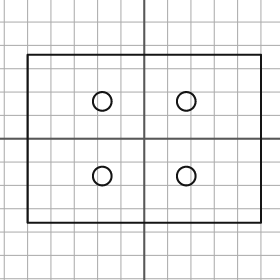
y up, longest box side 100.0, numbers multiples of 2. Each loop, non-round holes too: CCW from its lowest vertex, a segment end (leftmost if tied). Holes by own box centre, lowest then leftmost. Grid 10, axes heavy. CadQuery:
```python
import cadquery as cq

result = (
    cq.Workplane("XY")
    .moveTo(-50.0, -36.0)
    .lineTo(50.0, -36.0)
    .lineTo(50.0, 36.0)
    .lineTo(-50.0, 36.0)
    .close()
    .moveTo(-18.0, -16.0)
    .circle(4.0)
    .moveTo(18.0, -16.0)
    .circle(4.0)
    .moveTo(-18.0, 16.0)
    .circle(4.0)
    .moveTo(18.0, 16.0)
    .circle(4.0)
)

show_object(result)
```